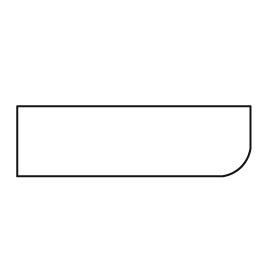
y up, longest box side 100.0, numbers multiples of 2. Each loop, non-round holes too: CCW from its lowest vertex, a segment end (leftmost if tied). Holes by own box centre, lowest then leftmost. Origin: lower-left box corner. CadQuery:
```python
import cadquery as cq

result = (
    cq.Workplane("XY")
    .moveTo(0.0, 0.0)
    .lineTo(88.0, 0.0)
    .threePointArc((96.0, 4.0), (100.0, 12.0))
    .lineTo(100.0, 30.0)
    .lineTo(0.0, 30.0)
    .close()
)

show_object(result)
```